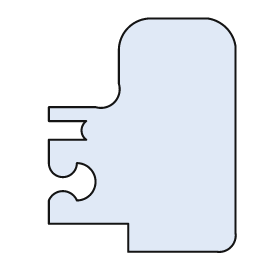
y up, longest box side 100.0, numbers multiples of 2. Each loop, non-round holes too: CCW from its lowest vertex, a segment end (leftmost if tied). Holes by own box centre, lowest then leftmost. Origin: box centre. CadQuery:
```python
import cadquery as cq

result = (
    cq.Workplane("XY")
    .moveTo(-6.0, -50.0)
    .lineTo(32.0, -50.0)
    .threePointArc((38.0, -48.0), (40.0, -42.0))
    .lineTo(40.0, 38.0)
    .threePointArc((36.0, 46.0), (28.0, 50.0))
    .lineTo(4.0, 50.0)
    .threePointArc((-6.0, 46.0), (-10.0, 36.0))
    .lineTo(-10.0, 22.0)
    .threePointArc((-12.0, 14.0), (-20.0, 12.0))
    .lineTo(-40.0, 12.0)
    .lineTo(-40.0, 6.0)
    .lineTo(-24.0, 6.0)
    .threePointArc((-26.0, 2.0), (-24.0, -2.0))
    .lineTo(-40.0, -2.0)
    .lineTo(-40.0, -12.0)
    .threePointArc((-34.0, -18.0), (-28.0, -12.0))
    .threePointArc((-20.0, -20.0), (-28.0, -28.0))
    .threePointArc((-34.0, -24.0), (-40.0, -28.0))
    .lineTo(-40.0, -38.0)
    .lineTo(-6.0, -38.0)
    .close()
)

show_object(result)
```